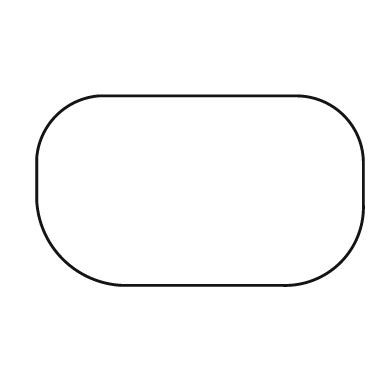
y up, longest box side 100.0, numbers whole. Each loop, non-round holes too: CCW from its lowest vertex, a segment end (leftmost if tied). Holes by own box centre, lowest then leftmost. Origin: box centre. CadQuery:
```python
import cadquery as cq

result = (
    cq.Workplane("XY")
    .moveTo(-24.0, -29.0)
    .lineTo(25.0, -29.0)
    .threePointArc((43.0, -22.0), (50.0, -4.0))
    .lineTo(50.0, 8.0)
    .threePointArc((44.0, 23.0), (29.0, 29.0))
    .lineTo(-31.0, 29.0)
    .threePointArc((-44.0, 23.0), (-50.0, 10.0))
    .lineTo(-50.0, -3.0)
    .threePointArc((-42.0, -21.0), (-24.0, -29.0))
    .close()
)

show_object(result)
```